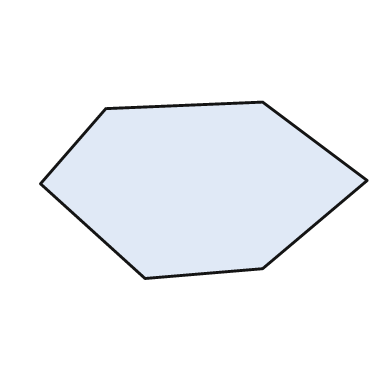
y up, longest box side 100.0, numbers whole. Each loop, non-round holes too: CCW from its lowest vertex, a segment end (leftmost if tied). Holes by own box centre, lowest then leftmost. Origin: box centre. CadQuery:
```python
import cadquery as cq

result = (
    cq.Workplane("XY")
    .moveTo(-18.0, -27.0)
    .lineTo(18.0, -24.0)
    .lineTo(50.0, 3.0)
    .lineTo(18.0, 27.0)
    .lineTo(-30.0, 25.0)
    .lineTo(-50.0, 2.0)
    .close()
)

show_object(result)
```